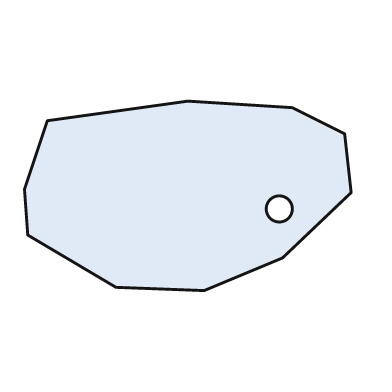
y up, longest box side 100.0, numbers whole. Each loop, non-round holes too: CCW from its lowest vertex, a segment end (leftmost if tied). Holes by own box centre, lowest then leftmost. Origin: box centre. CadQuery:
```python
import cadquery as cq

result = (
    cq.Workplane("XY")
    .moveTo(5.0, -29.0)
    .lineTo(29.0, -19.0)
    .lineTo(50.0, 1.0)
    .lineTo(48.0, 19.0)
    .lineTo(32.0, 27.0)
    .lineTo(0.0, 29.0)
    .lineTo(-43.0, 23.0)
    .lineTo(-50.0, 2.0)
    .lineTo(-49.0, -12.0)
    .lineTo(-22.0, -28.0)
    .close()
    .moveTo(28.0, -4.0)
    .circle(4.0)
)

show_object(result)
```